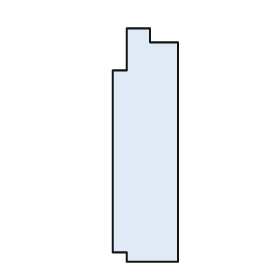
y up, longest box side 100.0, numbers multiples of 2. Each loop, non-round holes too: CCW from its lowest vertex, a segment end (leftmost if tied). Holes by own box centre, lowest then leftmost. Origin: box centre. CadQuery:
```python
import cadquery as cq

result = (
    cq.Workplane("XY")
    .moveTo(-8.0, -50.0)
    .lineTo(14.0, -50.0)
    .lineTo(14.0, 44.0)
    .lineTo(2.0, 44.0)
    .lineTo(2.0, 50.0)
    .lineTo(-8.0, 50.0)
    .lineTo(-8.0, 32.0)
    .lineTo(-14.0, 32.0)
    .lineTo(-14.0, -46.0)
    .lineTo(-8.0, -46.0)
    .close()
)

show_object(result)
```